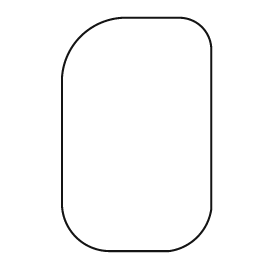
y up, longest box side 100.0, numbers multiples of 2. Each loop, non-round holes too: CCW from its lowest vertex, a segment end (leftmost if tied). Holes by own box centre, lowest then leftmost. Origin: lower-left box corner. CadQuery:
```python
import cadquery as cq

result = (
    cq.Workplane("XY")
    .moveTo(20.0, 0.0)
    .lineTo(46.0, 0.0)
    .threePointArc((58.0, 6.0), (64.0, 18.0))
    .lineTo(64.0, 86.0)
    .threePointArc((60.0, 96.0), (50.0, 100.0))
    .lineTo(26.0, 100.0)
    .threePointArc((8.0, 92.0), (0.0, 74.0))
    .lineTo(0.0, 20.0)
    .threePointArc((6.0, 6.0), (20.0, 0.0))
    .close()
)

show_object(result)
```